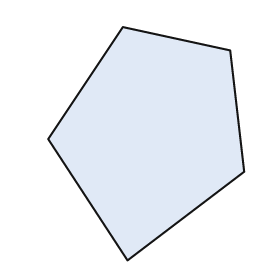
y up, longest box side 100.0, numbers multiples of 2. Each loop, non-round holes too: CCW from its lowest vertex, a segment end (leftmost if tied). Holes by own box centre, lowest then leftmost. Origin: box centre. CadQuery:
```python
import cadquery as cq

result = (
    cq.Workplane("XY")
    .moveTo(-8.0, -50.0)
    .lineTo(42.0, -12.0)
    .lineTo(36.0, 40.0)
    .lineTo(-10.0, 50.0)
    .lineTo(-42.0, 2.0)
    .close()
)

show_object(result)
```